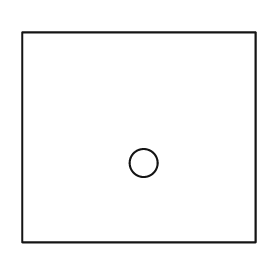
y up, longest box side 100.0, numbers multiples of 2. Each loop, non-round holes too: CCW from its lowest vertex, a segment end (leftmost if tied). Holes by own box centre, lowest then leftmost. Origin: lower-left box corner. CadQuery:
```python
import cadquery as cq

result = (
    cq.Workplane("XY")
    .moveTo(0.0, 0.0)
    .lineTo(100.0, 0.0)
    .lineTo(100.0, 90.0)
    .lineTo(0.0, 90.0)
    .close()
    .moveTo(52.0, 34.0)
    .circle(6.0)
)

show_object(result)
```